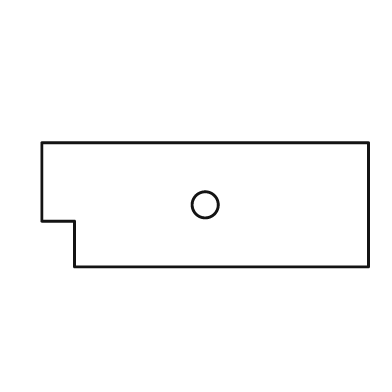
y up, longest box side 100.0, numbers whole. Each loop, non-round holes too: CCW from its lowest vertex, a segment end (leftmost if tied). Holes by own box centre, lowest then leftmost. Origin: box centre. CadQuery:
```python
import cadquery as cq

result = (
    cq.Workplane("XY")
    .moveTo(-40.0, -19.0)
    .lineTo(50.0, -19.0)
    .lineTo(50.0, 19.0)
    .lineTo(-50.0, 19.0)
    .lineTo(-50.0, -5.0)
    .lineTo(-40.0, -5.0)
    .close()
    .moveTo(0.0, 0.0)
    .circle(4.0)
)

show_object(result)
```